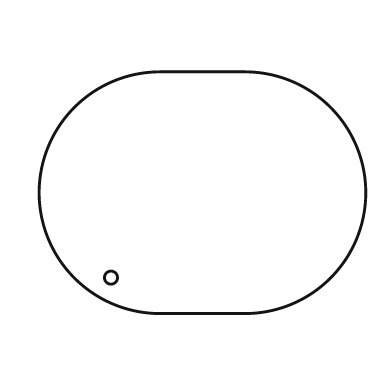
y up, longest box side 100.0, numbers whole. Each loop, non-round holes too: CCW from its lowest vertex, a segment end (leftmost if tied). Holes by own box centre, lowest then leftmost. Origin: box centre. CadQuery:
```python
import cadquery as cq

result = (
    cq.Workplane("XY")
    .moveTo(-13.0, -37.0)
    .lineTo(13.0, -37.0)
    .threePointArc((50.0, 0.0), (13.0, 37.0))
    .lineTo(-13.0, 37.0)
    .threePointArc((-50.0, 0.0), (-13.0, -37.0))
    .close()
    .moveTo(-28.0, -26.0)
    .circle(2.0)
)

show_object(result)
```